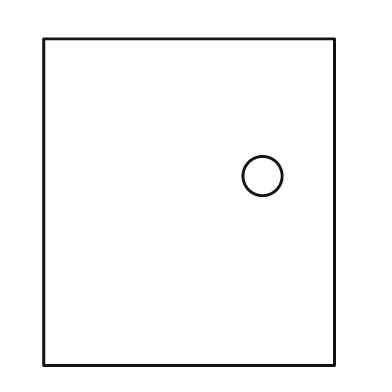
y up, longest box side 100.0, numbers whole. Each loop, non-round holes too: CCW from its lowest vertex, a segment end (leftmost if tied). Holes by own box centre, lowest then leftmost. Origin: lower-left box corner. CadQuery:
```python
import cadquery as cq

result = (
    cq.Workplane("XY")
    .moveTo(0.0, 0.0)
    .lineTo(89.0, 0.0)
    .lineTo(89.0, 100.0)
    .lineTo(0.0, 100.0)
    .close()
    .moveTo(67.0, 58.0)
    .circle(6.0)
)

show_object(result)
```